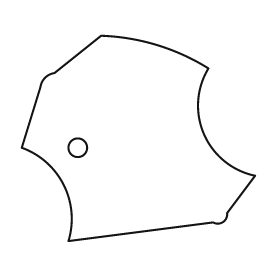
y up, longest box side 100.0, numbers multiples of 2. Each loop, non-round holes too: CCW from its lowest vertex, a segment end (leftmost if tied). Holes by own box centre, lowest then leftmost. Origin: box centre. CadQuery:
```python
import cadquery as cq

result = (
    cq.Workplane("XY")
    .moveTo(-30.0, -44.0)
    .lineTo(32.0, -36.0)
    .threePointArc((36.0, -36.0), (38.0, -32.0))
    .lineTo(50.0, -16.0)
    .threePointArc((28.0, 2.0), (30.0, 30.0))
    .threePointArc((8.0, 40.0), (-16.0, 44.0))
    .lineTo(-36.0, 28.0)
    .threePointArc((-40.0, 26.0), (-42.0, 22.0))
    .lineTo(-50.0, -4.0)
    .threePointArc((-32.0, -20.0), (-30.0, -44.0))
    .close()
    .moveTo(-26.0, -4.0)
    .circle(4.0)
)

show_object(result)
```